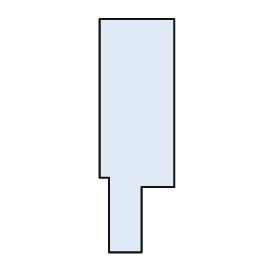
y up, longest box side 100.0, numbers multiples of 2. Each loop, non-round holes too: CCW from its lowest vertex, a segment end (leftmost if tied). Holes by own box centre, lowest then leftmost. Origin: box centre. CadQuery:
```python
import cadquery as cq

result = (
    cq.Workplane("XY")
    .moveTo(-12.0, -50.0)
    .lineTo(2.0, -50.0)
    .lineTo(2.0, -22.0)
    .lineTo(16.0, -22.0)
    .lineTo(16.0, 50.0)
    .lineTo(-16.0, 50.0)
    .lineTo(-16.0, -18.0)
    .lineTo(-12.0, -18.0)
    .close()
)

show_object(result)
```